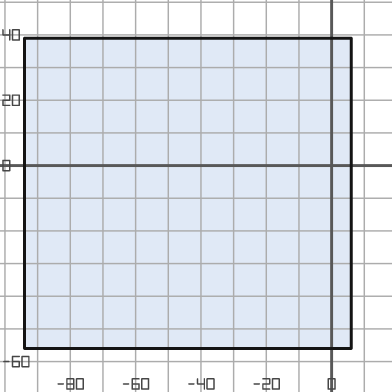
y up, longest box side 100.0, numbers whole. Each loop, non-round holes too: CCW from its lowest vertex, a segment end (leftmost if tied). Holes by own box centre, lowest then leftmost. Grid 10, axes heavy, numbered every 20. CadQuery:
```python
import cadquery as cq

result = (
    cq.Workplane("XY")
    .moveTo(-94.0, -56.0)
    .lineTo(6.0, -56.0)
    .lineTo(6.0, 39.0)
    .lineTo(-94.0, 39.0)
    .close()
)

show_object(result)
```